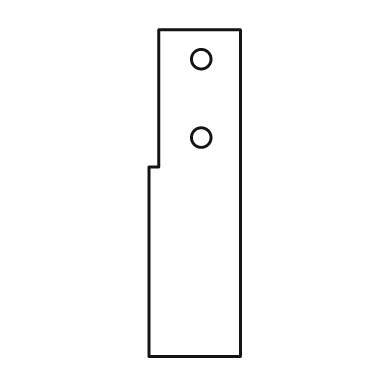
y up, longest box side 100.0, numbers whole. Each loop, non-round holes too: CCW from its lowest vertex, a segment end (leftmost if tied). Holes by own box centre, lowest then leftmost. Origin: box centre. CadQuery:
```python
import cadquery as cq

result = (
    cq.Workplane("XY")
    .moveTo(-14.0, -50.0)
    .lineTo(14.0, -50.0)
    .lineTo(14.0, 50.0)
    .lineTo(-11.0, 50.0)
    .lineTo(-11.0, 8.0)
    .lineTo(-14.0, 8.0)
    .close()
    .moveTo(2.0, 17.0)
    .circle(3.0)
    .moveTo(2.0, 41.0)
    .circle(3.0)
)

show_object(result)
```